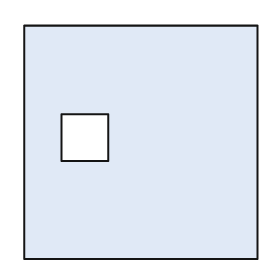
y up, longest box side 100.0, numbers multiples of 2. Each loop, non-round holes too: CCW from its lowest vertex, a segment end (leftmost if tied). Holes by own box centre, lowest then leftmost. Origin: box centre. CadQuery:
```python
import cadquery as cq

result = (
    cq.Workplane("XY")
    .moveTo(-50.0, -50.0)
    .lineTo(50.0, -50.0)
    .lineTo(50.0, 50.0)
    .lineTo(-50.0, 50.0)
    .close()
    .moveTo(-34.0, -8.0)
    .lineTo(-14.0, -8.0)
    .lineTo(-14.0, 12.0)
    .lineTo(-34.0, 12.0)
    .close()
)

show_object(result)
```